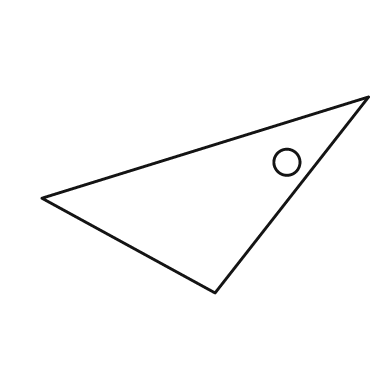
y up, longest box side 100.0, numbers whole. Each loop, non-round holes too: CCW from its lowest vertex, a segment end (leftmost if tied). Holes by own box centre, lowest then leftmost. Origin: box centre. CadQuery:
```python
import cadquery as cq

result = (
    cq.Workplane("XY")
    .moveTo(3.0, -30.0)
    .lineTo(50.0, 30.0)
    .lineTo(-50.0, -1.0)
    .close()
    .moveTo(25.0, 10.0)
    .circle(4.0)
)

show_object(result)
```